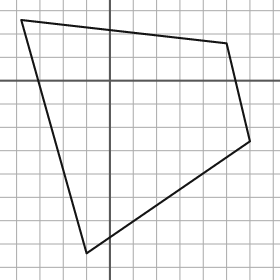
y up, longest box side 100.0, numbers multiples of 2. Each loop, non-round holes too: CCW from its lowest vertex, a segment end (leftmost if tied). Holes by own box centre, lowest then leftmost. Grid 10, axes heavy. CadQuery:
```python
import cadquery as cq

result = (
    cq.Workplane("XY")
    .moveTo(-10.0, -74.0)
    .lineTo(60.0, -26.0)
    .lineTo(50.0, 16.0)
    .lineTo(-38.0, 26.0)
    .close()
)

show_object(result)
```